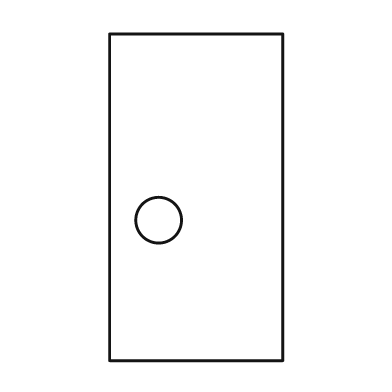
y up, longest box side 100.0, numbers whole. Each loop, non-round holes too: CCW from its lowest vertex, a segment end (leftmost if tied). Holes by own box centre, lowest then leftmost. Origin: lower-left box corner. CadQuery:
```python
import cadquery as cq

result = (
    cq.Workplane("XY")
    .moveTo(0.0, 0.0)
    .lineTo(53.0, 0.0)
    .lineTo(53.0, 100.0)
    .lineTo(0.0, 100.0)
    .close()
    .moveTo(15.0, 43.0)
    .circle(7.0)
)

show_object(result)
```